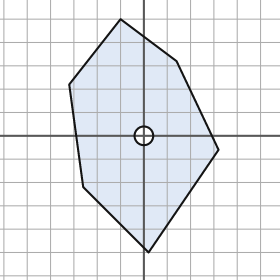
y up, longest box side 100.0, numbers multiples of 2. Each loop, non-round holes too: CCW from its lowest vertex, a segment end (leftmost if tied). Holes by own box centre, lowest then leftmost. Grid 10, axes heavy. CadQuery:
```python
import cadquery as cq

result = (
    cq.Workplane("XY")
    .moveTo(2.0, -50.0)
    .lineTo(32.0, -6.0)
    .lineTo(14.0, 32.0)
    .lineTo(-10.0, 50.0)
    .lineTo(-32.0, 22.0)
    .lineTo(-26.0, -22.0)
    .close()
    .moveTo(0.0, 0.0)
    .circle(4.0)
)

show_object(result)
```